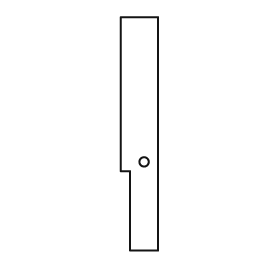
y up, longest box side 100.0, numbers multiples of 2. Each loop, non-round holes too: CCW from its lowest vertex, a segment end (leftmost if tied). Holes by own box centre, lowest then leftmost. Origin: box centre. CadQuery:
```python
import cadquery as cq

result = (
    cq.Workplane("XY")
    .moveTo(-4.0, -50.0)
    .lineTo(8.0, -50.0)
    .lineTo(8.0, 50.0)
    .lineTo(-8.0, 50.0)
    .lineTo(-8.0, -16.0)
    .lineTo(-4.0, -16.0)
    .close()
    .moveTo(2.0, -12.0)
    .circle(2.0)
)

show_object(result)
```